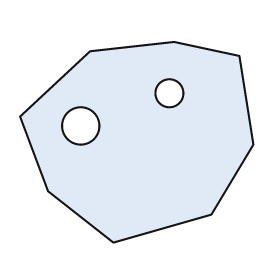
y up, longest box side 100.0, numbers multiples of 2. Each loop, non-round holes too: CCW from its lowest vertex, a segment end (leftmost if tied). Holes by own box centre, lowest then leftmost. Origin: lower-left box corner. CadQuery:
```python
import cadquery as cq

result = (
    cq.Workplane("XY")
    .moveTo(40.0, 0.0)
    .lineTo(82.0, 12.0)
    .lineTo(100.0, 42.0)
    .lineTo(94.0, 80.0)
    .lineTo(66.0, 86.0)
    .lineTo(30.0, 82.0)
    .lineTo(0.0, 54.0)
    .lineTo(12.0, 22.0)
    .close()
    .moveTo(26.0, 50.0)
    .circle(8.0)
    .moveTo(64.0, 64.0)
    .circle(6.0)
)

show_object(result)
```